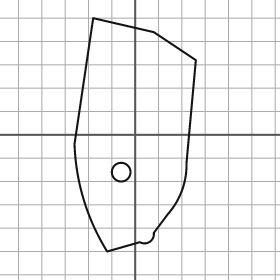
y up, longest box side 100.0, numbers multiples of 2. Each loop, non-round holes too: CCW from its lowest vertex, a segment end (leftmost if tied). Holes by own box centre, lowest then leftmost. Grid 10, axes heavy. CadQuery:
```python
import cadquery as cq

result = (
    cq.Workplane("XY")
    .moveTo(-12.0, -50.0)
    .lineTo(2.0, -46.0)
    .threePointArc((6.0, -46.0), (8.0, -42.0))
    .lineTo(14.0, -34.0)
    .threePointArc((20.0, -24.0), (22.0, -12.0))
    .lineTo(26.0, 32.0)
    .lineTo(8.0, 44.0)
    .lineTo(-18.0, 50.0)
    .lineTo(-26.0, -4.0)
    .threePointArc((-22.0, -28.0), (-12.0, -50.0))
    .close()
    .moveTo(-6.0, -16.0)
    .circle(4.0)
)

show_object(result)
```